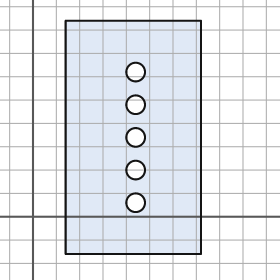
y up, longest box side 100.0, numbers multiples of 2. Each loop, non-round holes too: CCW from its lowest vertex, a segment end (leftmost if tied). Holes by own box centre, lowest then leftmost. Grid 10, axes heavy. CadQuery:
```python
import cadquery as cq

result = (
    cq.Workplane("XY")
    .moveTo(14.0, -16.0)
    .lineTo(72.0, -16.0)
    .lineTo(72.0, 84.0)
    .lineTo(14.0, 84.0)
    .close()
    .moveTo(44.0, 6.0)
    .circle(4.0)
    .moveTo(44.0, 20.0)
    .circle(4.0)
    .moveTo(44.0, 34.0)
    .circle(4.0)
    .moveTo(44.0, 48.0)
    .circle(4.0)
    .moveTo(44.0, 62.0)
    .circle(4.0)
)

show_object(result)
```